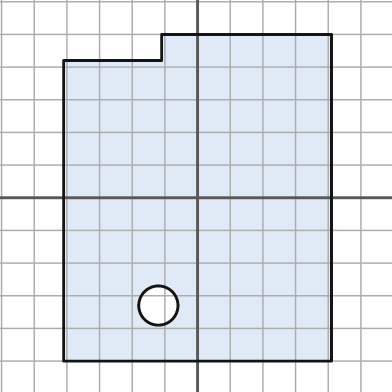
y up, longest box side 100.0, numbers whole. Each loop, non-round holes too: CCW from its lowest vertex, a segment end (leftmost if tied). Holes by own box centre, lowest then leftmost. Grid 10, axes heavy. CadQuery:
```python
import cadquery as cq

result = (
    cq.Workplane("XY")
    .moveTo(-41.0, -50.0)
    .lineTo(41.0, -50.0)
    .lineTo(41.0, 50.0)
    .lineTo(-11.0, 50.0)
    .lineTo(-11.0, 42.0)
    .lineTo(-41.0, 42.0)
    .close()
    .moveTo(-12.0, -33.0)
    .circle(6.0)
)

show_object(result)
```